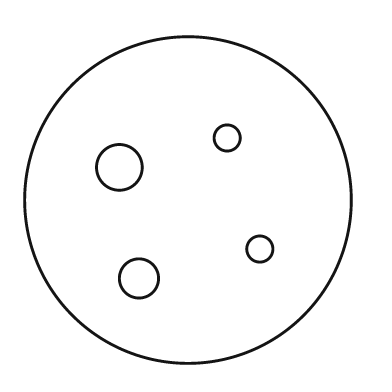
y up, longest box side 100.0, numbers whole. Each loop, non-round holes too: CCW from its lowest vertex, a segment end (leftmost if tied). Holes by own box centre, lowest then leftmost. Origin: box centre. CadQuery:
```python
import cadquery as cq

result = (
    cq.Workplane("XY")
    .moveTo(0.0, 0.0)
    .circle(50.0)
    .moveTo(-15.0, -24.0)
    .circle(6.0)
    .moveTo(22.0, -15.0)
    .circle(4.0)
    .moveTo(-21.0, 10.0)
    .circle(7.0)
    .moveTo(12.0, 19.0)
    .circle(4.0)
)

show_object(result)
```